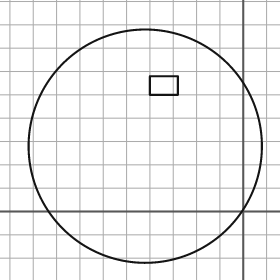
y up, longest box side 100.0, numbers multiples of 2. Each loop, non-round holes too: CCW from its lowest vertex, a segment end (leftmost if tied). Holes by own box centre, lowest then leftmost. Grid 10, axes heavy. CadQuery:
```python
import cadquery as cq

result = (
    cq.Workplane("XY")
    .moveTo(-42.0, 28.0)
    .circle(50.0)
    .moveTo(-40.0, 50.0)
    .lineTo(-28.0, 50.0)
    .lineTo(-28.0, 58.0)
    .lineTo(-40.0, 58.0)
    .close()
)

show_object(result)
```